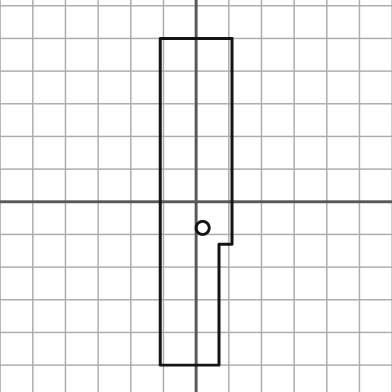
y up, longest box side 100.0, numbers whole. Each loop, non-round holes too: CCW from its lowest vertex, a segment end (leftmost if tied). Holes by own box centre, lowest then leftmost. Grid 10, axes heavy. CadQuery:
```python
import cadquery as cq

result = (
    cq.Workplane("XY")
    .moveTo(-11.0, -50.0)
    .lineTo(7.0, -50.0)
    .lineTo(7.0, -13.0)
    .lineTo(11.0, -13.0)
    .lineTo(11.0, 50.0)
    .lineTo(-11.0, 50.0)
    .close()
    .moveTo(2.0, -8.0)
    .circle(2.0)
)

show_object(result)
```